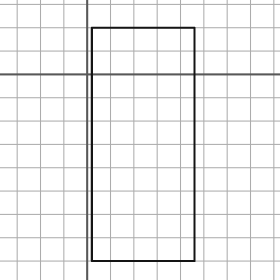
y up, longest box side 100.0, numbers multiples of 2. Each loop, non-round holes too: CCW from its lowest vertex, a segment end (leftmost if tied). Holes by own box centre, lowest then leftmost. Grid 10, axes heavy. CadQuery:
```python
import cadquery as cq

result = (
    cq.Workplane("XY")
    .moveTo(2.0, -80.0)
    .lineTo(46.0, -80.0)
    .lineTo(46.0, 20.0)
    .lineTo(2.0, 20.0)
    .close()
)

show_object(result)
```